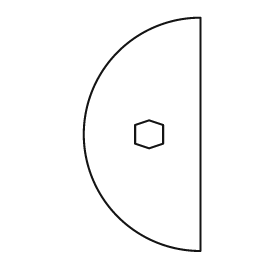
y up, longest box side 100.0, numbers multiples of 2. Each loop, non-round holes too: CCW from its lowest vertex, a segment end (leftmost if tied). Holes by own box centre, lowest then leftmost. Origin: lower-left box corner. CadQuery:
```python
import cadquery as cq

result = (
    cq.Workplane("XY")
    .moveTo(50.0, 0.0)
    .lineTo(50.0, 100.0)
    .threePointArc((0.0, 50.0), (50.0, 0.0))
    .close()
    .moveTo(28.0, 44.0)
    .lineTo(34.0, 46.0)
    .lineTo(34.0, 54.0)
    .lineTo(28.0, 56.0)
    .lineTo(22.0, 54.0)
    .lineTo(22.0, 46.0)
    .close()
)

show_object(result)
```